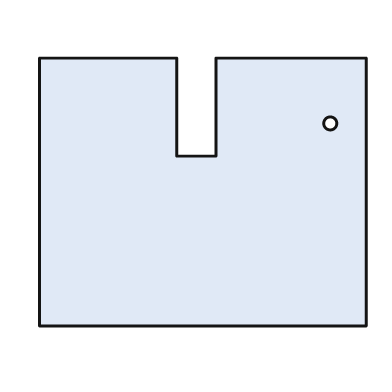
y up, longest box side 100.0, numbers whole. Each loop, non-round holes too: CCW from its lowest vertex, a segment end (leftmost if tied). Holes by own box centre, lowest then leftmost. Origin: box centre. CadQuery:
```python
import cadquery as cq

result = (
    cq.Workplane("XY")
    .moveTo(-50.0, -41.0)
    .lineTo(50.0, -41.0)
    .lineTo(50.0, 41.0)
    .lineTo(4.0, 41.0)
    .lineTo(4.0, 11.0)
    .lineTo(-8.0, 11.0)
    .lineTo(-8.0, 41.0)
    .lineTo(-50.0, 41.0)
    .close()
    .moveTo(39.0, 21.0)
    .circle(2.0)
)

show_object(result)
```